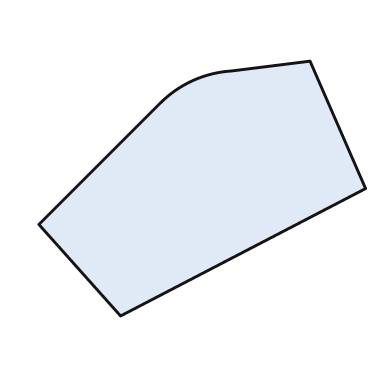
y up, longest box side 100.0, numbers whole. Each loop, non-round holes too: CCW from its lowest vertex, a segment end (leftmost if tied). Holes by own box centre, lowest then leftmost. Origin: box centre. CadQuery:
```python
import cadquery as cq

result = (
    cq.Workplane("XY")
    .moveTo(-25.0, -39.0)
    .lineTo(50.0, 0.0)
    .lineTo(33.0, 39.0)
    .lineTo(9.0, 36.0)
    .threePointArc((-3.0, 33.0), (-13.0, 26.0))
    .lineTo(-50.0, -11.0)
    .close()
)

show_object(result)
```